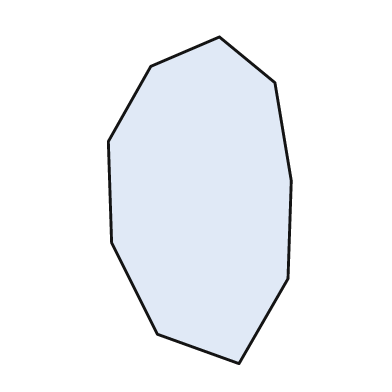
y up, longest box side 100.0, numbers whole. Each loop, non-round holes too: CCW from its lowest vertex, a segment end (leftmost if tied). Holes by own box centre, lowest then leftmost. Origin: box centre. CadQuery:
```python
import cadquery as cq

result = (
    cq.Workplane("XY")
    .moveTo(12.0, -50.0)
    .lineTo(27.0, -24.0)
    .lineTo(28.0, 6.0)
    .lineTo(23.0, 36.0)
    .lineTo(6.0, 50.0)
    .lineTo(-15.0, 41.0)
    .lineTo(-28.0, 18.0)
    .lineTo(-27.0, -13.0)
    .lineTo(-13.0, -41.0)
    .close()
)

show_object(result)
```